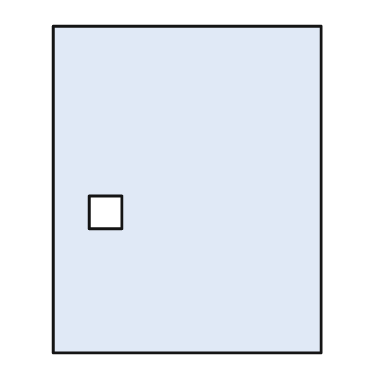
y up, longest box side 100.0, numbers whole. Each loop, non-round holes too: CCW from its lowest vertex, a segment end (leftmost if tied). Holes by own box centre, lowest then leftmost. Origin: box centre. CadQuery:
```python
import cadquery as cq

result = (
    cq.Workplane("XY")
    .moveTo(-41.0, -50.0)
    .lineTo(41.0, -50.0)
    .lineTo(41.0, 50.0)
    .lineTo(-41.0, 50.0)
    .close()
    .moveTo(-30.0, -12.0)
    .lineTo(-20.0, -12.0)
    .lineTo(-20.0, -2.0)
    .lineTo(-30.0, -2.0)
    .close()
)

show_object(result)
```